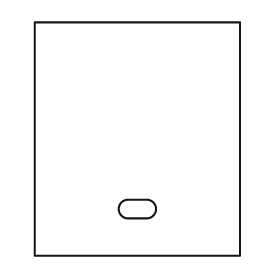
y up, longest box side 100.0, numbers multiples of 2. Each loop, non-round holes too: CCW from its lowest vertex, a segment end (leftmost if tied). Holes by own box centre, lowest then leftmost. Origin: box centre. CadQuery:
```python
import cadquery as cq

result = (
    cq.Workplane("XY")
    .moveTo(-44.0, -50.0)
    .lineTo(44.0, -50.0)
    .lineTo(44.0, 50.0)
    .lineTo(-44.0, 50.0)
    .close()
    .moveTo(-4.0, -34.0)
    .lineTo(4.0, -34.0)
    .threePointArc((8.0, -30.0), (4.0, -26.0))
    .lineTo(-4.0, -26.0)
    .threePointArc((-8.0, -30.0), (-4.0, -34.0))
    .close()
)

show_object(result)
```